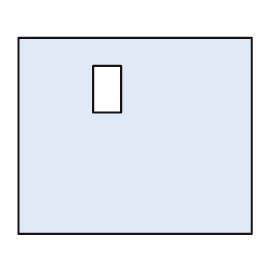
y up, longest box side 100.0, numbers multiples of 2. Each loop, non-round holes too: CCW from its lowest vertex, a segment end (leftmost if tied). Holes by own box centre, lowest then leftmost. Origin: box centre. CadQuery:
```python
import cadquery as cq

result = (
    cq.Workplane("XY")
    .moveTo(-50.0, -42.0)
    .lineTo(50.0, -42.0)
    .lineTo(50.0, 42.0)
    .lineTo(-50.0, 42.0)
    .close()
    .moveTo(-18.0, 10.0)
    .lineTo(-6.0, 10.0)
    .lineTo(-6.0, 30.0)
    .lineTo(-18.0, 30.0)
    .close()
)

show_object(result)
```